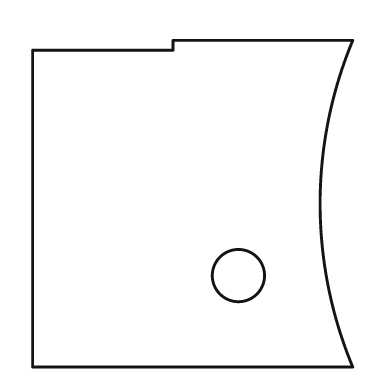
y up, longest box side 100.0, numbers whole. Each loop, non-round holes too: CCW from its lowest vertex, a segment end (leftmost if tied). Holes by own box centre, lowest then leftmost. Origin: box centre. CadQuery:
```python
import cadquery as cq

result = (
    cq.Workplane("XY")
    .moveTo(-49.0, -50.0)
    .lineTo(49.0, -50.0)
    .threePointArc((39.0, 0.0), (49.0, 50.0))
    .lineTo(-6.0, 50.0)
    .lineTo(-6.0, 47.0)
    .lineTo(-49.0, 47.0)
    .close()
    .moveTo(14.0, -22.0)
    .circle(8.0)
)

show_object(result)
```